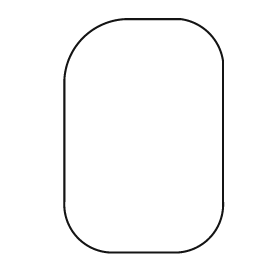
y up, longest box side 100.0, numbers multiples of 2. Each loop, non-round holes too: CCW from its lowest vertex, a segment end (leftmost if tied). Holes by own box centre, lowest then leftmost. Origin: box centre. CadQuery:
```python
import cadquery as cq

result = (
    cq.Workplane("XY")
    .moveTo(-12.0, -50.0)
    .lineTo(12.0, -50.0)
    .threePointArc((28.0, -44.0), (34.0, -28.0))
    .lineTo(34.0, 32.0)
    .threePointArc((28.0, 44.0), (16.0, 50.0))
    .lineTo(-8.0, 50.0)
    .threePointArc((-26.0, 42.0), (-34.0, 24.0))
    .lineTo(-34.0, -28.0)
    .threePointArc((-28.0, -44.0), (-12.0, -50.0))
    .close()
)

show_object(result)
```